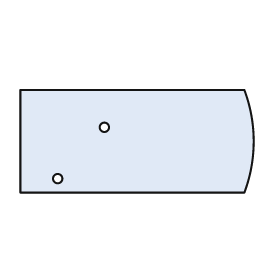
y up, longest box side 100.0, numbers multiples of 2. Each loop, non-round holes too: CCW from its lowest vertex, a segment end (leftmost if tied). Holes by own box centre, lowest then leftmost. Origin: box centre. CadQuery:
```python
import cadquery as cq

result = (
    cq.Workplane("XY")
    .moveTo(-50.0, -22.0)
    .lineTo(46.0, -22.0)
    .threePointArc((50.0, 0.0), (46.0, 22.0))
    .lineTo(-50.0, 22.0)
    .close()
    .moveTo(-34.0, -16.0)
    .circle(2.0)
    .moveTo(-14.0, 6.0)
    .circle(2.0)
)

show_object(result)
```